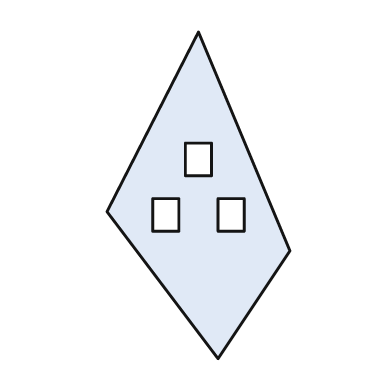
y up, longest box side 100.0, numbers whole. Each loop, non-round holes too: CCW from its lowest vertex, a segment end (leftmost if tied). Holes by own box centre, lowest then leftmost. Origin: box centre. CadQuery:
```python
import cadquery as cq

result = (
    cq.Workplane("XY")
    .moveTo(6.0, -50.0)
    .lineTo(28.0, -17.0)
    .lineTo(0.0, 50.0)
    .lineTo(-28.0, -5.0)
    .close()
    .moveTo(-14.0, -11.0)
    .lineTo(-6.0, -11.0)
    .lineTo(-6.0, -1.0)
    .lineTo(-14.0, -1.0)
    .close()
    .moveTo(6.0, -11.0)
    .lineTo(14.0, -11.0)
    .lineTo(14.0, -1.0)
    .lineTo(6.0, -1.0)
    .close()
    .moveTo(-4.0, 6.0)
    .lineTo(4.0, 6.0)
    .lineTo(4.0, 16.0)
    .lineTo(-4.0, 16.0)
    .close()
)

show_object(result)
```